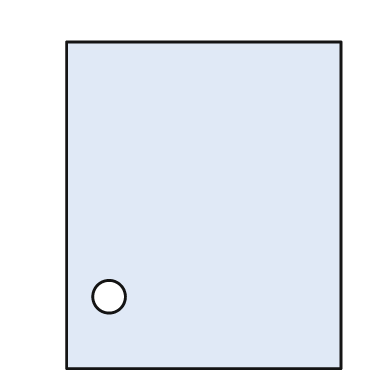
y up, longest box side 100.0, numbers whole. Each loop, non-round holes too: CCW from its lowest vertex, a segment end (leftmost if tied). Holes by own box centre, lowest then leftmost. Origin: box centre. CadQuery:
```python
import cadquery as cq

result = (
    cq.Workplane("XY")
    .moveTo(-42.0, -50.0)
    .lineTo(42.0, -50.0)
    .lineTo(42.0, 50.0)
    .lineTo(-42.0, 50.0)
    .close()
    .moveTo(-29.0, -28.0)
    .circle(5.0)
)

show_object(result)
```